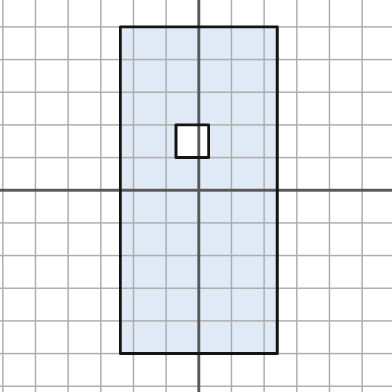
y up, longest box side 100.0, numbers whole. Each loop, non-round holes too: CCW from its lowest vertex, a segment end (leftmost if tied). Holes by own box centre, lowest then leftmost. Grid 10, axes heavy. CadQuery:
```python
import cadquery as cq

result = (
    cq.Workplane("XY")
    .moveTo(-24.0, -50.0)
    .lineTo(24.0, -50.0)
    .lineTo(24.0, 50.0)
    .lineTo(-24.0, 50.0)
    .close()
    .moveTo(-7.0, 10.0)
    .lineTo(3.0, 10.0)
    .lineTo(3.0, 20.0)
    .lineTo(-7.0, 20.0)
    .close()
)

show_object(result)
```